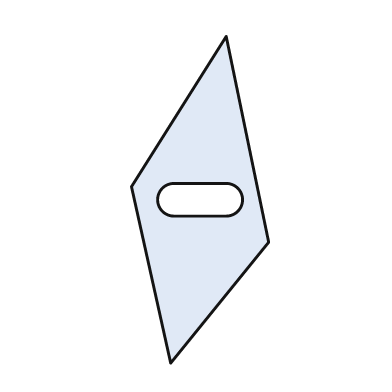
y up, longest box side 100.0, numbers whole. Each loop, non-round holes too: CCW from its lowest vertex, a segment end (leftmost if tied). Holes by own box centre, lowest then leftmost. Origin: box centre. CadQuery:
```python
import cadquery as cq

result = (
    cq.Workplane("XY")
    .moveTo(-9.0, -50.0)
    .lineTo(21.0, -13.0)
    .lineTo(8.0, 50.0)
    .lineTo(-21.0, 4.0)
    .close()
    .moveTo(-8.0, -5.0)
    .lineTo(8.0, -5.0)
    .threePointArc((13.0, 0.0), (8.0, 5.0))
    .lineTo(-8.0, 5.0)
    .threePointArc((-13.0, 0.0), (-8.0, -5.0))
    .close()
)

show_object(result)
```